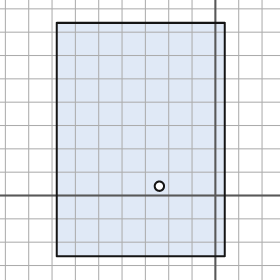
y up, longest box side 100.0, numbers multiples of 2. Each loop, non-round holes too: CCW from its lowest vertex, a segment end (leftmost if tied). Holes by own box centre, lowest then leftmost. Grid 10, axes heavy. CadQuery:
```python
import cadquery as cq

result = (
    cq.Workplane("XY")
    .moveTo(-68.0, -26.0)
    .lineTo(4.0, -26.0)
    .lineTo(4.0, 74.0)
    .lineTo(-68.0, 74.0)
    .close()
    .moveTo(-24.0, 4.0)
    .circle(2.0)
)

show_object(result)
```